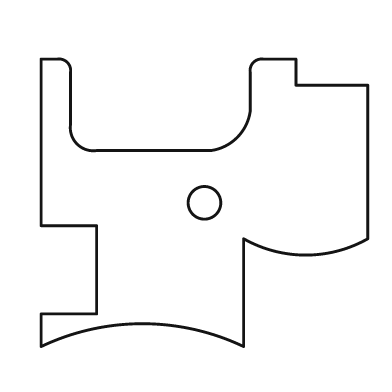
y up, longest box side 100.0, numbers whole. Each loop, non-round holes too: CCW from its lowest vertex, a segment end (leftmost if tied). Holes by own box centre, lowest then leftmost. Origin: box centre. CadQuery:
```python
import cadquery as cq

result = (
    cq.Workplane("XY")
    .moveTo(-50.0, -44.0)
    .threePointArc((-19.0, -37.0), (12.0, -44.0))
    .lineTo(12.0, -11.0)
    .threePointArc((31.0, -16.0), (50.0, -11.0))
    .lineTo(50.0, 36.0)
    .lineTo(28.0, 36.0)
    .lineTo(28.0, 44.0)
    .lineTo(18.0, 44.0)
    .threePointArc((15.0, 43.0), (14.0, 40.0))
    .lineTo(14.0, 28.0)
    .threePointArc((10.0, 20.0), (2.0, 16.0))
    .lineTo(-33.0, 16.0)
    .threePointArc((-39.0, 18.0), (-41.0, 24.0))
    .lineTo(-41.0, 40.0)
    .threePointArc((-42.0, 43.0), (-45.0, 44.0))
    .lineTo(-50.0, 44.0)
    .lineTo(-50.0, -7.0)
    .lineTo(-33.0, -7.0)
    .lineTo(-33.0, -34.0)
    .lineTo(-50.0, -34.0)
    .close()
    .moveTo(0.0, 0.0)
    .circle(5.0)
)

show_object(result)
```